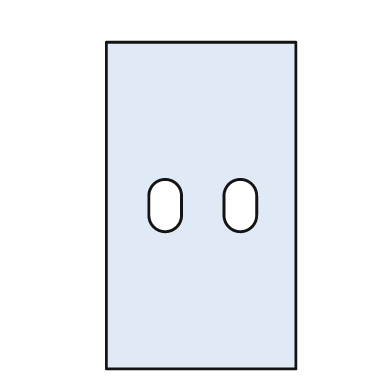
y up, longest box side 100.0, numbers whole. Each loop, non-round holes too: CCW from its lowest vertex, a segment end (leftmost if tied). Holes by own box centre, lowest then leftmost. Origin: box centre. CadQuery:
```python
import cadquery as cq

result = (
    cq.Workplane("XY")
    .moveTo(-29.0, -50.0)
    .lineTo(29.0, -50.0)
    .lineTo(29.0, 50.0)
    .lineTo(-29.0, 50.0)
    .close()
    .moveTo(-16.0, -3.0)
    .threePointArc((-11.0, -8.0), (-6.0, -3.0))
    .lineTo(-6.0, 3.0)
    .threePointArc((-11.0, 8.0), (-16.0, 3.0))
    .close()
    .moveTo(7.0, -3.0)
    .threePointArc((12.0, -8.0), (17.0, -3.0))
    .lineTo(17.0, 3.0)
    .threePointArc((12.0, 8.0), (7.0, 3.0))
    .close()
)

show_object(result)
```